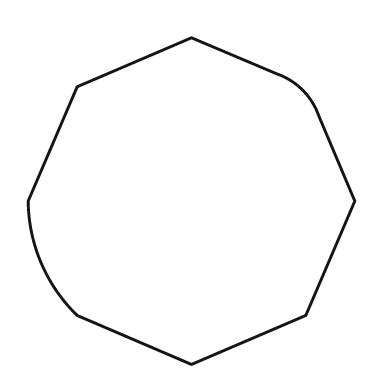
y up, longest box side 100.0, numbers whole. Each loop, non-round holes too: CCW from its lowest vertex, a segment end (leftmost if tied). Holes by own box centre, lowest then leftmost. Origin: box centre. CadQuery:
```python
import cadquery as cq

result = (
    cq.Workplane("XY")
    .moveTo(0.0, -50.0)
    .lineTo(35.0, -35.0)
    .lineTo(50.0, 0.0)
    .lineTo(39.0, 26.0)
    .threePointArc((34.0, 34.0), (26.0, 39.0))
    .lineTo(0.0, 50.0)
    .lineTo(-35.0, 35.0)
    .lineTo(-50.0, 0.0)
    .threePointArc((-46.0, -19.0), (-35.0, -35.0))
    .close()
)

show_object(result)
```